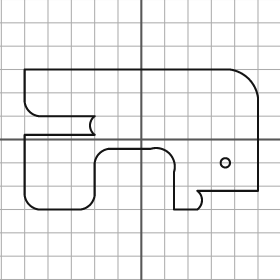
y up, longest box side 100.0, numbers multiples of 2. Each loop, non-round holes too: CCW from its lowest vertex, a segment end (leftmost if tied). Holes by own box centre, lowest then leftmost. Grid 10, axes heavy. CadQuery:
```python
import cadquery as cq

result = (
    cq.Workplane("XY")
    .moveTo(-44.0, -30.0)
    .lineTo(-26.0, -30.0)
    .threePointArc((-22.0, -28.0), (-20.0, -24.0))
    .lineTo(-20.0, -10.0)
    .threePointArc((-18.0, -6.0), (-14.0, -4.0))
    .lineTo(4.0, -4.0)
    .threePointArc((12.0, -6.0), (14.0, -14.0))
    .lineTo(14.0, -30.0)
    .lineTo(24.0, -30.0)
    .threePointArc((26.0, -26.0), (24.0, -22.0))
    .lineTo(50.0, -22.0)
    .lineTo(50.0, 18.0)
    .threePointArc((46.0, 26.0), (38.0, 30.0))
    .lineTo(-50.0, 30.0)
    .lineTo(-50.0, 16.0)
    .threePointArc((-48.0, 12.0), (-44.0, 10.0))
    .lineTo(-20.0, 10.0)
    .threePointArc((-22.0, 6.0), (-20.0, 2.0))
    .lineTo(-50.0, 2.0)
    .lineTo(-50.0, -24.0)
    .threePointArc((-48.0, -28.0), (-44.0, -30.0))
    .close()
    .moveTo(36.0, -10.0)
    .circle(2.0)
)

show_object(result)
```